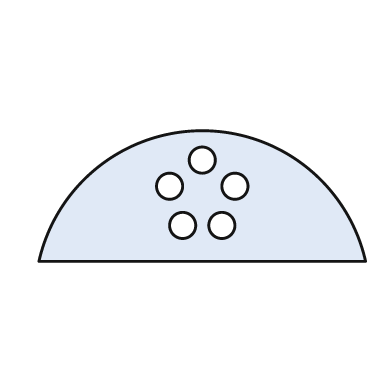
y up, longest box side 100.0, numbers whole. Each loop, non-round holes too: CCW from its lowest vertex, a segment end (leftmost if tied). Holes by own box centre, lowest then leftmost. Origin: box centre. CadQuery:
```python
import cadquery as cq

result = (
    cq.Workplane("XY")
    .moveTo(-50.0, -20.0)
    .lineTo(50.0, -20.0)
    .threePointArc((0.0, 20.0), (-50.0, -20.0))
    .close()
    .moveTo(-6.0, -9.0)
    .circle(4.0)
    .moveTo(6.0, -9.0)
    .circle(4.0)
    .moveTo(-10.0, 3.0)
    .circle(4.0)
    .moveTo(10.0, 3.0)
    .circle(4.0)
    .moveTo(0.0, 11.0)
    .circle(4.0)
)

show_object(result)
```